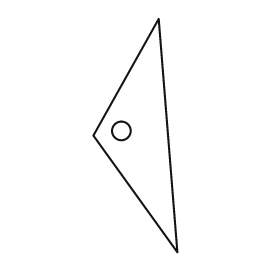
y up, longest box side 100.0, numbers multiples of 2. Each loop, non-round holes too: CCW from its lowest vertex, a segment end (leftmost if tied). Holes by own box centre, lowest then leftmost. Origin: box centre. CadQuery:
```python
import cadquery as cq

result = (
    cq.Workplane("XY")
    .moveTo(18.0, -50.0)
    .lineTo(10.0, 50.0)
    .lineTo(-18.0, 0.0)
    .close()
    .moveTo(-6.0, 2.0)
    .circle(4.0)
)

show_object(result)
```